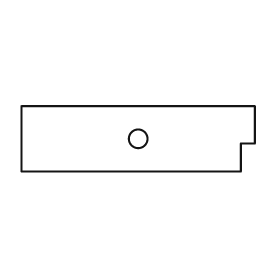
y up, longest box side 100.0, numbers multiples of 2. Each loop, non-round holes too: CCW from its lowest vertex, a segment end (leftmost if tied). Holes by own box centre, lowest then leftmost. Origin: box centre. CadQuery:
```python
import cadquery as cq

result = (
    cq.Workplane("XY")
    .moveTo(-50.0, -14.0)
    .lineTo(44.0, -14.0)
    .lineTo(44.0, -2.0)
    .lineTo(50.0, -2.0)
    .lineTo(50.0, 14.0)
    .lineTo(-50.0, 14.0)
    .close()
    .moveTo(0.0, 0.0)
    .circle(4.0)
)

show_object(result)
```